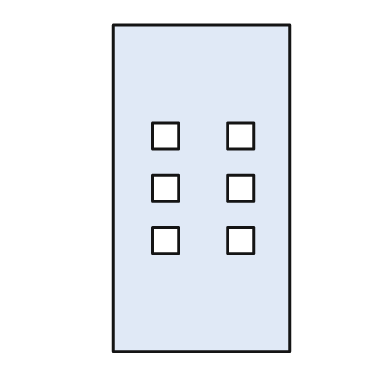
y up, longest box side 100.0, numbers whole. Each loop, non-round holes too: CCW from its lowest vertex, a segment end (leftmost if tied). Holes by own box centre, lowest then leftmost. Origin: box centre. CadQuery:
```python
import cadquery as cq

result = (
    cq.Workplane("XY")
    .moveTo(-27.0, -50.0)
    .lineTo(27.0, -50.0)
    .lineTo(27.0, 50.0)
    .lineTo(-27.0, 50.0)
    .close()
    .moveTo(-15.0, -20.0)
    .lineTo(-7.0, -20.0)
    .lineTo(-7.0, -12.0)
    .lineTo(-15.0, -12.0)
    .close()
    .moveTo(8.0, -20.0)
    .lineTo(16.0, -20.0)
    .lineTo(16.0, -12.0)
    .lineTo(8.0, -12.0)
    .close()
    .moveTo(-15.0, -4.0)
    .lineTo(-7.0, -4.0)
    .lineTo(-7.0, 4.0)
    .lineTo(-15.0, 4.0)
    .close()
    .moveTo(8.0, -4.0)
    .lineTo(16.0, -4.0)
    .lineTo(16.0, 4.0)
    .lineTo(8.0, 4.0)
    .close()
    .moveTo(-15.0, 12.0)
    .lineTo(-7.0, 12.0)
    .lineTo(-7.0, 20.0)
    .lineTo(-15.0, 20.0)
    .close()
    .moveTo(8.0, 12.0)
    .lineTo(16.0, 12.0)
    .lineTo(16.0, 20.0)
    .lineTo(8.0, 20.0)
    .close()
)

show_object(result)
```